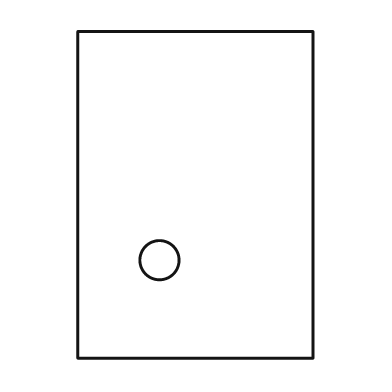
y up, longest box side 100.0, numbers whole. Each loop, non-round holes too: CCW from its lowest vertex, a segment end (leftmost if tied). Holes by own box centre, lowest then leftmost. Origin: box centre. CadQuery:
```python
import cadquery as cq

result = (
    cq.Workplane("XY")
    .moveTo(-36.0, -50.0)
    .lineTo(36.0, -50.0)
    .lineTo(36.0, 50.0)
    .lineTo(-36.0, 50.0)
    .close()
    .moveTo(-11.0, -20.0)
    .circle(6.0)
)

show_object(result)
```